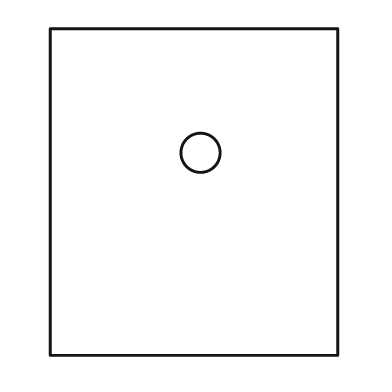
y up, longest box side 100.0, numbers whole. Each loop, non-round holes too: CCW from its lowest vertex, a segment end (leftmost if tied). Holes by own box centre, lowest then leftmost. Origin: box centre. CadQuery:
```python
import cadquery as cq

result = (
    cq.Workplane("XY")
    .moveTo(-44.0, -50.0)
    .lineTo(44.0, -50.0)
    .lineTo(44.0, 50.0)
    .lineTo(-44.0, 50.0)
    .close()
    .moveTo(2.0, 12.0)
    .circle(6.0)
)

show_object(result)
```